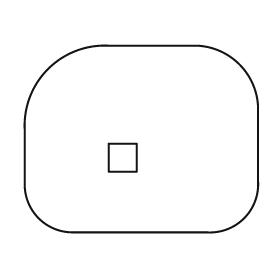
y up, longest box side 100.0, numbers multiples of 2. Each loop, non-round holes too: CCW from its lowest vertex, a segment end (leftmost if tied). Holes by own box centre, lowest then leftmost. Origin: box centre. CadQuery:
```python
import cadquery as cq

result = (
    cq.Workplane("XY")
    .moveTo(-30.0, -40.0)
    .lineTo(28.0, -40.0)
    .threePointArc((44.0, -34.0), (50.0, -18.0))
    .lineTo(50.0, 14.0)
    .threePointArc((42.0, 32.0), (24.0, 40.0))
    .lineTo(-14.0, 40.0)
    .threePointArc((-40.0, 30.0), (-50.0, 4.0))
    .lineTo(-50.0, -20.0)
    .threePointArc((-44.0, -34.0), (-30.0, -40.0))
    .close()
    .moveTo(-14.0, -14.0)
    .lineTo(-2.0, -14.0)
    .lineTo(-2.0, -2.0)
    .lineTo(-14.0, -2.0)
    .close()
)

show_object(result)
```